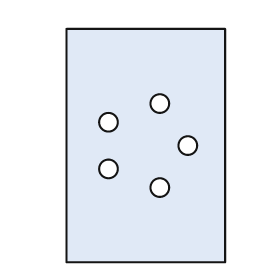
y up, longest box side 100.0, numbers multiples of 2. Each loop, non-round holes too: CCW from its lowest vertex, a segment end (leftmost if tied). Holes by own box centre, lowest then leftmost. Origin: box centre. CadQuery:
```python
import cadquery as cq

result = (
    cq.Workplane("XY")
    .moveTo(-34.0, -50.0)
    .lineTo(34.0, -50.0)
    .lineTo(34.0, 50.0)
    .lineTo(-34.0, 50.0)
    .close()
    .moveTo(6.0, -18.0)
    .circle(4.0)
    .moveTo(-16.0, -10.0)
    .circle(4.0)
    .moveTo(18.0, 0.0)
    .circle(4.0)
    .moveTo(-16.0, 10.0)
    .circle(4.0)
    .moveTo(6.0, 18.0)
    .circle(4.0)
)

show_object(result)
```